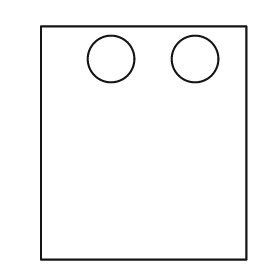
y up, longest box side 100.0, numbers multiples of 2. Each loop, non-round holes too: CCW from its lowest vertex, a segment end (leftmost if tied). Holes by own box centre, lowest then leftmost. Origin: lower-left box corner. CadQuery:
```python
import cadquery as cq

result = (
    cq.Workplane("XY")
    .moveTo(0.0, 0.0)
    .lineTo(88.0, 0.0)
    .lineTo(88.0, 100.0)
    .lineTo(0.0, 100.0)
    .close()
    .moveTo(30.0, 86.0)
    .circle(10.0)
    .moveTo(66.0, 86.0)
    .circle(10.0)
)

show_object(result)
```